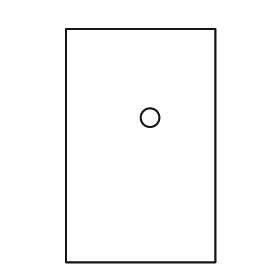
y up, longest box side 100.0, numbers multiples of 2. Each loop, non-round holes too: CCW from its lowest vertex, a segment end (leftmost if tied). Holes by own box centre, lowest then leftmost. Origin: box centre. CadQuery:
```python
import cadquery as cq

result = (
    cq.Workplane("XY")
    .moveTo(-32.0, -50.0)
    .lineTo(32.0, -50.0)
    .lineTo(32.0, 50.0)
    .lineTo(-32.0, 50.0)
    .close()
    .moveTo(4.0, 12.0)
    .circle(4.0)
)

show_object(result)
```